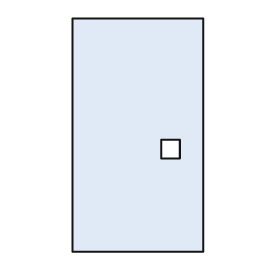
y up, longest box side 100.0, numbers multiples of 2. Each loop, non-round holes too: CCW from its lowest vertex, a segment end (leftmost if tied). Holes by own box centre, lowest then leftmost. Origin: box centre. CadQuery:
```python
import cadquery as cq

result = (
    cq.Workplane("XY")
    .moveTo(-28.0, -50.0)
    .lineTo(28.0, -50.0)
    .lineTo(28.0, 50.0)
    .lineTo(-28.0, 50.0)
    .close()
    .moveTo(10.0, -10.0)
    .lineTo(18.0, -10.0)
    .lineTo(18.0, -2.0)
    .lineTo(10.0, -2.0)
    .close()
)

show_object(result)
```